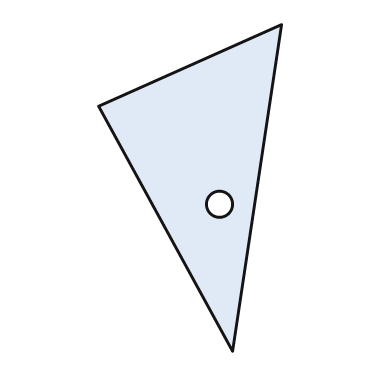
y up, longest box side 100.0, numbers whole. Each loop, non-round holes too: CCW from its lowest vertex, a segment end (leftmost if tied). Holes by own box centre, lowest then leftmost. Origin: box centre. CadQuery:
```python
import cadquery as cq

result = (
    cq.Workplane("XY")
    .moveTo(13.0, -50.0)
    .lineTo(28.0, 50.0)
    .lineTo(-28.0, 25.0)
    .close()
    .moveTo(9.0, -5.0)
    .circle(4.0)
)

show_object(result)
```